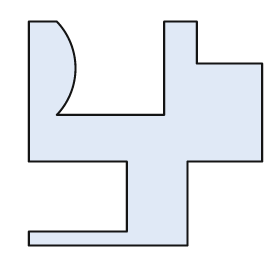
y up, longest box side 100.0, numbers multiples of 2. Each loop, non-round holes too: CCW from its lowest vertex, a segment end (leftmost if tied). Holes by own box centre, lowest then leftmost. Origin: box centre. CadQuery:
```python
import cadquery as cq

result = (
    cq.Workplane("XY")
    .moveTo(-50.0, -48.0)
    .lineTo(18.0, -48.0)
    .lineTo(18.0, -12.0)
    .lineTo(50.0, -12.0)
    .lineTo(50.0, 30.0)
    .lineTo(22.0, 30.0)
    .lineTo(22.0, 48.0)
    .lineTo(8.0, 48.0)
    .lineTo(8.0, 8.0)
    .lineTo(-38.0, 8.0)
    .threePointArc((-30.0, 28.0), (-38.0, 48.0))
    .lineTo(-50.0, 48.0)
    .lineTo(-50.0, -12.0)
    .lineTo(-8.0, -12.0)
    .lineTo(-8.0, -42.0)
    .lineTo(-50.0, -42.0)
    .close()
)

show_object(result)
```